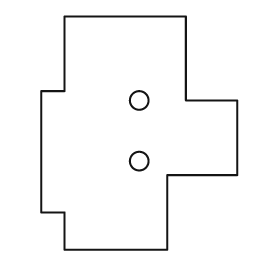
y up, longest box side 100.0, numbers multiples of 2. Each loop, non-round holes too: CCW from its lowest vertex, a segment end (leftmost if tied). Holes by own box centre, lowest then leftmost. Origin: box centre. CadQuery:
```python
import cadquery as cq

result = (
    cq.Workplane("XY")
    .moveTo(-32.0, -50.0)
    .lineTo(12.0, -50.0)
    .lineTo(12.0, -18.0)
    .lineTo(42.0, -18.0)
    .lineTo(42.0, 14.0)
    .lineTo(20.0, 14.0)
    .lineTo(20.0, 50.0)
    .lineTo(-32.0, 50.0)
    .lineTo(-32.0, 18.0)
    .lineTo(-42.0, 18.0)
    .lineTo(-42.0, -34.0)
    .lineTo(-32.0, -34.0)
    .close()
    .moveTo(0.0, -12.0)
    .circle(4.0)
    .moveTo(0.0, 14.0)
    .circle(4.0)
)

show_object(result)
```